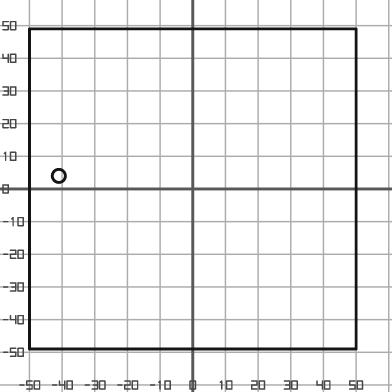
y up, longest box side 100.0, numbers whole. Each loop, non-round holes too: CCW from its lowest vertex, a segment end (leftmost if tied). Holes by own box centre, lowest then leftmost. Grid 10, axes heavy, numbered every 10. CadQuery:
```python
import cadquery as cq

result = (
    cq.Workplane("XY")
    .moveTo(-50.0, -49.0)
    .lineTo(50.0, -49.0)
    .lineTo(50.0, 49.0)
    .lineTo(-50.0, 49.0)
    .close()
    .moveTo(-41.0, 4.0)
    .circle(2.0)
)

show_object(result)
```